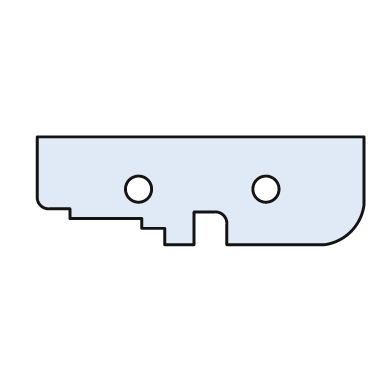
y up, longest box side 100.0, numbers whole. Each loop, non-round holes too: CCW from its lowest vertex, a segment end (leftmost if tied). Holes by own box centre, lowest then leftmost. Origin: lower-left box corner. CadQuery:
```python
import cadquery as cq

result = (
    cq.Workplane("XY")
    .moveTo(39.0, 0.0)
    .lineTo(48.0, 0.0)
    .lineTo(48.0, 10.0)
    .lineTo(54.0, 10.0)
    .threePointArc((57.0, 9.0), (58.0, 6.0))
    .lineTo(58.0, 0.0)
    .lineTo(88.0, 0.0)
    .threePointArc((96.0, 4.0), (100.0, 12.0))
    .lineTo(100.0, 33.0)
    .lineTo(0.0, 33.0)
    .lineTo(0.0, 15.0)
    .threePointArc((1.0, 12.0), (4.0, 11.0))
    .lineTo(10.0, 11.0)
    .lineTo(10.0, 8.0)
    .lineTo(32.0, 8.0)
    .lineTo(32.0, 5.0)
    .lineTo(39.0, 5.0)
    .close()
    .moveTo(31.0, 17.0)
    .circle(4.0)
    .moveTo(70.0, 17.0)
    .circle(4.0)
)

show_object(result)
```